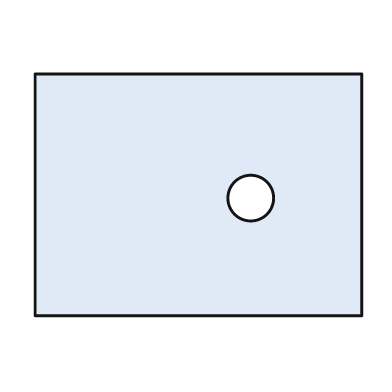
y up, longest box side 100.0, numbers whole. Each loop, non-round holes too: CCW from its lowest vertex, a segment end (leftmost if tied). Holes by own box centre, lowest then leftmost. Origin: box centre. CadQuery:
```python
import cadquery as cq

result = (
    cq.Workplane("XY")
    .moveTo(-50.0, -37.0)
    .lineTo(50.0, -37.0)
    .lineTo(50.0, 37.0)
    .lineTo(-50.0, 37.0)
    .close()
    .moveTo(16.0, -1.0)
    .circle(7.0)
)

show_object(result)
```